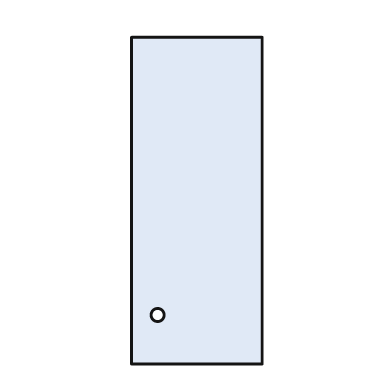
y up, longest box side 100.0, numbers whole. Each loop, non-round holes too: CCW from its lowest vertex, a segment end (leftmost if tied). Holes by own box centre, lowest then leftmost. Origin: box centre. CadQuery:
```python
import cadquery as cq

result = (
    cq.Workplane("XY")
    .moveTo(-20.0, -50.0)
    .lineTo(20.0, -50.0)
    .lineTo(20.0, 50.0)
    .lineTo(-20.0, 50.0)
    .close()
    .moveTo(-12.0, -35.0)
    .circle(2.0)
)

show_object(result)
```